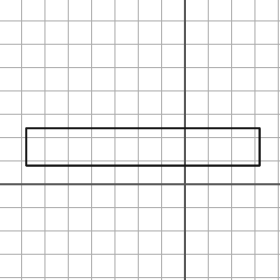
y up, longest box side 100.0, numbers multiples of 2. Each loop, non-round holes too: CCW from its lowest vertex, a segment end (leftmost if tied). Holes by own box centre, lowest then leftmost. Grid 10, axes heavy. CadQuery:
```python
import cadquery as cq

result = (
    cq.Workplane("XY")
    .moveTo(-68.0, 8.0)
    .lineTo(32.0, 8.0)
    .lineTo(32.0, 24.0)
    .lineTo(-68.0, 24.0)
    .close()
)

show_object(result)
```